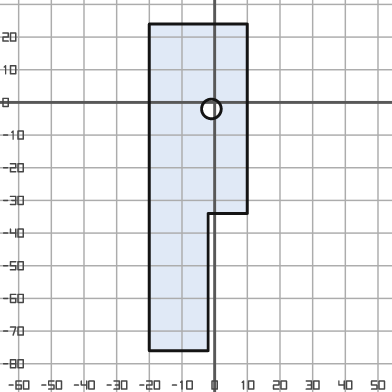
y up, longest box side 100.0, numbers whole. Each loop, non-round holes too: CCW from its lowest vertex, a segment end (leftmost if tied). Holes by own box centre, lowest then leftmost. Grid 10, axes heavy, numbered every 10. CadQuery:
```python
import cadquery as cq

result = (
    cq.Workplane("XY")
    .moveTo(-20.0, -76.0)
    .lineTo(-2.0, -76.0)
    .lineTo(-2.0, -34.0)
    .lineTo(10.0, -34.0)
    .lineTo(10.0, 24.0)
    .lineTo(-20.0, 24.0)
    .close()
    .moveTo(-1.0, -2.0)
    .circle(3.0)
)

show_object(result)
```